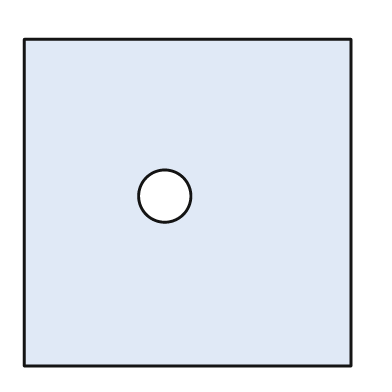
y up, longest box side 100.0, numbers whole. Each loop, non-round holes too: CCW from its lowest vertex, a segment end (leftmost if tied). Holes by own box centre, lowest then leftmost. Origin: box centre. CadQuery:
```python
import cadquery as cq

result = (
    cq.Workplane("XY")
    .moveTo(-50.0, -50.0)
    .lineTo(50.0, -50.0)
    .lineTo(50.0, 50.0)
    .lineTo(-50.0, 50.0)
    .close()
    .moveTo(-7.0, 2.0)
    .circle(8.0)
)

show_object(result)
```